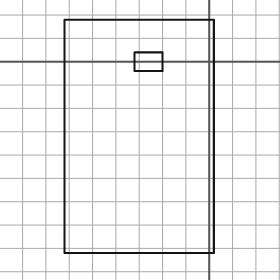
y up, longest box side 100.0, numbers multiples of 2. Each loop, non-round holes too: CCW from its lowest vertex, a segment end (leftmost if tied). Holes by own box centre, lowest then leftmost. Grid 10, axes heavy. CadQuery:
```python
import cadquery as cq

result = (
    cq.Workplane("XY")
    .moveTo(-62.0, -82.0)
    .lineTo(2.0, -82.0)
    .lineTo(2.0, 18.0)
    .lineTo(-62.0, 18.0)
    .close()
    .moveTo(-32.0, -4.0)
    .lineTo(-20.0, -4.0)
    .lineTo(-20.0, 4.0)
    .lineTo(-32.0, 4.0)
    .close()
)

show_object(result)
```